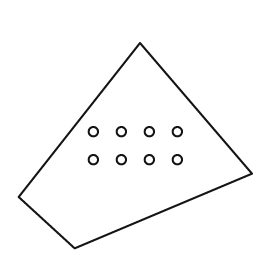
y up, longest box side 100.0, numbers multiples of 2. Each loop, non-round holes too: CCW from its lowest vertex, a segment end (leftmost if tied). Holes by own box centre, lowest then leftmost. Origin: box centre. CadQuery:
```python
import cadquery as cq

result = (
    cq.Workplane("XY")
    .moveTo(-26.0, -44.0)
    .lineTo(50.0, -12.0)
    .lineTo(2.0, 44.0)
    .lineTo(-50.0, -22.0)
    .close()
    .moveTo(-18.0, -6.0)
    .circle(2.0)
    .moveTo(-6.0, -6.0)
    .circle(2.0)
    .moveTo(6.0, -6.0)
    .circle(2.0)
    .moveTo(18.0, -6.0)
    .circle(2.0)
    .moveTo(-18.0, 6.0)
    .circle(2.0)
    .moveTo(-6.0, 6.0)
    .circle(2.0)
    .moveTo(6.0, 6.0)
    .circle(2.0)
    .moveTo(18.0, 6.0)
    .circle(2.0)
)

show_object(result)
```